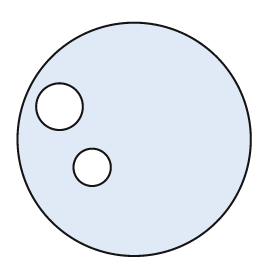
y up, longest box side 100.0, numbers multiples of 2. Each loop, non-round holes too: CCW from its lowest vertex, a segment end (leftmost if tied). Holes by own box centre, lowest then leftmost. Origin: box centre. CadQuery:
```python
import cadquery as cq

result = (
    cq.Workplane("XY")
    .moveTo(0.0, 0.0)
    .circle(50.0)
    .moveTo(-18.0, -12.0)
    .circle(8.0)
    .moveTo(-32.0, 14.0)
    .circle(10.0)
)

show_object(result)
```